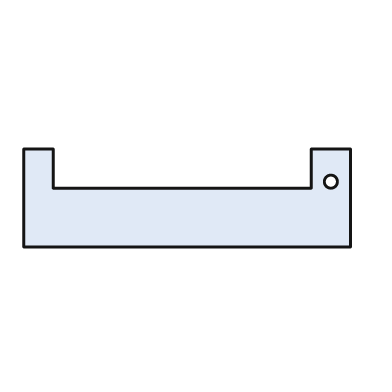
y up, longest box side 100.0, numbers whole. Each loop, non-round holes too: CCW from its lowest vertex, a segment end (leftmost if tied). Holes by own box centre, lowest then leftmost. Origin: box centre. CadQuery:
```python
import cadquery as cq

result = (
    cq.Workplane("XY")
    .moveTo(-50.0, -15.0)
    .lineTo(50.0, -15.0)
    .lineTo(50.0, 15.0)
    .lineTo(38.0, 15.0)
    .lineTo(38.0, 3.0)
    .lineTo(-41.0, 3.0)
    .lineTo(-41.0, 15.0)
    .lineTo(-50.0, 15.0)
    .close()
    .moveTo(44.0, 5.0)
    .circle(2.0)
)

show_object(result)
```